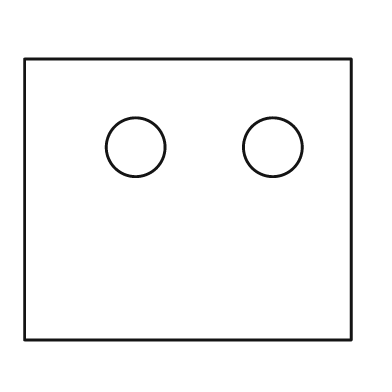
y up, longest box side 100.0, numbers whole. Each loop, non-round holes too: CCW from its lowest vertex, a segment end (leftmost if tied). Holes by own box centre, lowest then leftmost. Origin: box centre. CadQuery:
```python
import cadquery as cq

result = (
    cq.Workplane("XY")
    .moveTo(-50.0, -43.0)
    .lineTo(50.0, -43.0)
    .lineTo(50.0, 43.0)
    .lineTo(-50.0, 43.0)
    .close()
    .moveTo(-16.0, 16.0)
    .circle(9.0)
    .moveTo(26.0, 16.0)
    .circle(9.0)
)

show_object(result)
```